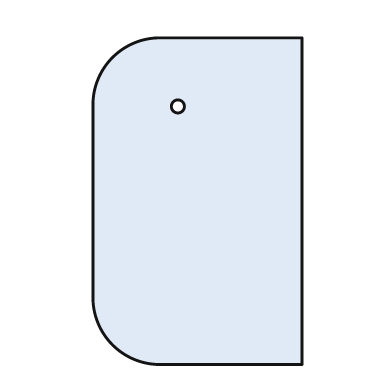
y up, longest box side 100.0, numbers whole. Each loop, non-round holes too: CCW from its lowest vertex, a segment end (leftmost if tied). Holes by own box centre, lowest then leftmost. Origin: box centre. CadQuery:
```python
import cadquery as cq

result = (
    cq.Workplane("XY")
    .moveTo(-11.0, -50.0)
    .lineTo(32.0, -50.0)
    .lineTo(32.0, 50.0)
    .lineTo(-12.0, 50.0)
    .threePointArc((-26.0, 44.0), (-32.0, 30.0))
    .lineTo(-32.0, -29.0)
    .threePointArc((-26.0, -44.0), (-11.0, -50.0))
    .close()
    .moveTo(-6.0, 29.0)
    .circle(2.0)
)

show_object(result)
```